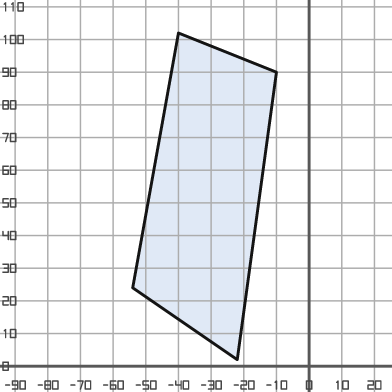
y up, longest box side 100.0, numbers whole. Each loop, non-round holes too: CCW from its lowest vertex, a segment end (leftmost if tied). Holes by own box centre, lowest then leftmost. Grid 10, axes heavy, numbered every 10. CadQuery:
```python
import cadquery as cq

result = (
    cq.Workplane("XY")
    .moveTo(-22.0, 2.0)
    .lineTo(-10.0, 90.0)
    .lineTo(-40.0, 102.0)
    .lineTo(-54.0, 24.0)
    .close()
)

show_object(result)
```